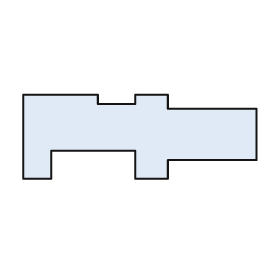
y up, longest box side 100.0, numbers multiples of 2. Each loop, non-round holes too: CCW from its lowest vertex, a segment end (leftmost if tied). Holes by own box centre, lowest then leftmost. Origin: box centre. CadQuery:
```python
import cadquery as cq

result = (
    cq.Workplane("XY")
    .moveTo(-50.0, -18.0)
    .lineTo(-38.0, -18.0)
    .lineTo(-38.0, -6.0)
    .lineTo(-2.0, -6.0)
    .lineTo(-2.0, -18.0)
    .lineTo(12.0, -18.0)
    .lineTo(12.0, -10.0)
    .lineTo(50.0, -10.0)
    .lineTo(50.0, 12.0)
    .lineTo(12.0, 12.0)
    .lineTo(12.0, 18.0)
    .lineTo(-2.0, 18.0)
    .lineTo(-2.0, 14.0)
    .lineTo(-18.0, 14.0)
    .lineTo(-18.0, 18.0)
    .lineTo(-50.0, 18.0)
    .close()
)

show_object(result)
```